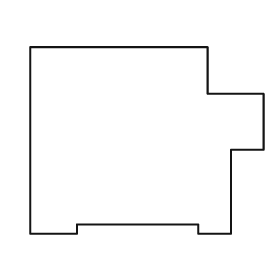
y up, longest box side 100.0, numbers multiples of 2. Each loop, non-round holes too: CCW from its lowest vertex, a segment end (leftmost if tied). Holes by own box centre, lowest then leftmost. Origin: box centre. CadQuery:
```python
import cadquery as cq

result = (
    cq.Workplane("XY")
    .moveTo(-50.0, -40.0)
    .lineTo(-30.0, -40.0)
    .lineTo(-30.0, -36.0)
    .lineTo(22.0, -36.0)
    .lineTo(22.0, -40.0)
    .lineTo(36.0, -40.0)
    .lineTo(36.0, -4.0)
    .lineTo(50.0, -4.0)
    .lineTo(50.0, 20.0)
    .lineTo(26.0, 20.0)
    .lineTo(26.0, 40.0)
    .lineTo(-50.0, 40.0)
    .close()
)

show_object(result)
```